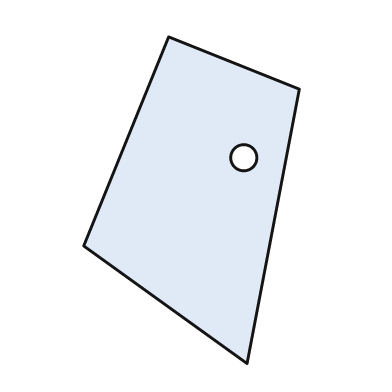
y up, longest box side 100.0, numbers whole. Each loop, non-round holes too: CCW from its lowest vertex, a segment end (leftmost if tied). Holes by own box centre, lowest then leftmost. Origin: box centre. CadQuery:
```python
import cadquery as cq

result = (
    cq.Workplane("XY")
    .moveTo(17.0, -50.0)
    .lineTo(33.0, 34.0)
    .lineTo(-7.0, 50.0)
    .lineTo(-33.0, -14.0)
    .close()
    .moveTo(16.0, 13.0)
    .circle(4.0)
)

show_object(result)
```